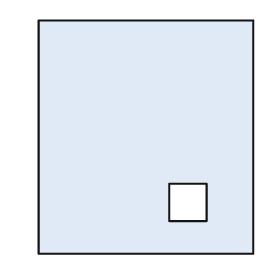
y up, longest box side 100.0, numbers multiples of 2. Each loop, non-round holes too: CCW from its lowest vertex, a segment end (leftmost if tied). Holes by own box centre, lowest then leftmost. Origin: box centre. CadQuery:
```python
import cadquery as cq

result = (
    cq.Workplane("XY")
    .moveTo(-46.0, -50.0)
    .lineTo(46.0, -50.0)
    .lineTo(46.0, 50.0)
    .lineTo(-46.0, 50.0)
    .close()
    .moveTo(10.0, -36.0)
    .lineTo(26.0, -36.0)
    .lineTo(26.0, -20.0)
    .lineTo(10.0, -20.0)
    .close()
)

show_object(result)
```